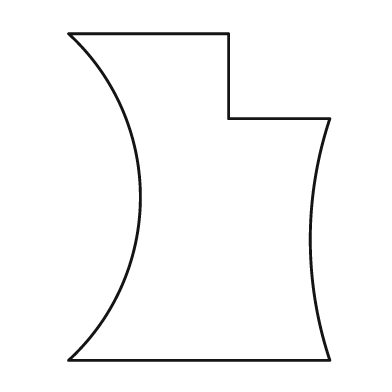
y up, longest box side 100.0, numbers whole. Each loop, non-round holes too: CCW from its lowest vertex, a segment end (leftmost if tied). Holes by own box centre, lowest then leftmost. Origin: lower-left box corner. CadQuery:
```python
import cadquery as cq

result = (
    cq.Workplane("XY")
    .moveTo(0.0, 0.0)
    .lineTo(80.0, 0.0)
    .threePointArc((74.0, 37.0), (80.0, 74.0))
    .lineTo(49.0, 74.0)
    .lineTo(49.0, 100.0)
    .lineTo(0.0, 100.0)
    .threePointArc((22.0, 50.0), (0.0, 0.0))
    .close()
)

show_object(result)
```